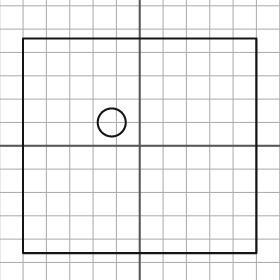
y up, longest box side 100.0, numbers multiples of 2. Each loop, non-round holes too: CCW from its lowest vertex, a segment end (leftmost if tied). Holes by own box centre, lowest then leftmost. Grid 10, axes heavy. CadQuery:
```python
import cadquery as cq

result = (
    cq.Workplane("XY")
    .moveTo(-50.0, -46.0)
    .lineTo(50.0, -46.0)
    .lineTo(50.0, 46.0)
    .lineTo(-50.0, 46.0)
    .close()
    .moveTo(-12.0, 10.0)
    .circle(6.0)
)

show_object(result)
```